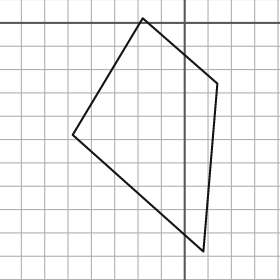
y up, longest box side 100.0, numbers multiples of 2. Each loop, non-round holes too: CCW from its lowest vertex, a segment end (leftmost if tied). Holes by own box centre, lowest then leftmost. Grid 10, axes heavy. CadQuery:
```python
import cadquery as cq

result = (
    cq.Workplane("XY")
    .moveTo(8.0, -98.0)
    .lineTo(14.0, -26.0)
    .lineTo(-18.0, 2.0)
    .lineTo(-48.0, -48.0)
    .close()
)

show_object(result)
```